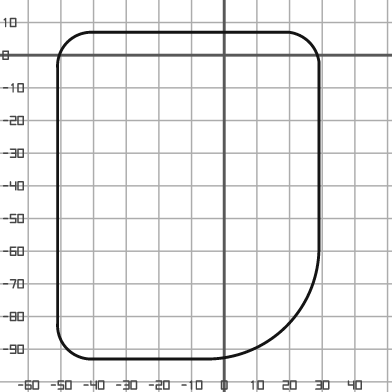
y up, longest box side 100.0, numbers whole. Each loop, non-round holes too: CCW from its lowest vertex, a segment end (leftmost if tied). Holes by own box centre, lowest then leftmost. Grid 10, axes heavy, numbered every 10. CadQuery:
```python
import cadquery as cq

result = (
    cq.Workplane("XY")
    .moveTo(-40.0, -93.0)
    .lineTo(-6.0, -93.0)
    .threePointArc((19.0, -83.0), (29.0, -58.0))
    .lineTo(29.0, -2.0)
    .threePointArc((26.0, 4.0), (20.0, 7.0))
    .lineTo(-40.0, 7.0)
    .threePointArc((-48.0, 4.0), (-51.0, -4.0))
    .lineTo(-51.0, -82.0)
    .threePointArc((-48.0, -90.0), (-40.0, -93.0))
    .close()
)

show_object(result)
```